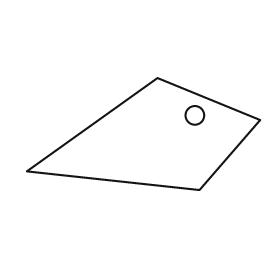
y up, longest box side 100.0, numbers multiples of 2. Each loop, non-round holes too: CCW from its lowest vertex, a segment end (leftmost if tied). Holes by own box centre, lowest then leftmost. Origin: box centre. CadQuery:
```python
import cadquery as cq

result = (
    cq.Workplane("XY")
    .moveTo(24.0, -24.0)
    .lineTo(50.0, 6.0)
    .lineTo(6.0, 24.0)
    .lineTo(-50.0, -16.0)
    .close()
    .moveTo(22.0, 8.0)
    .circle(4.0)
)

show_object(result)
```